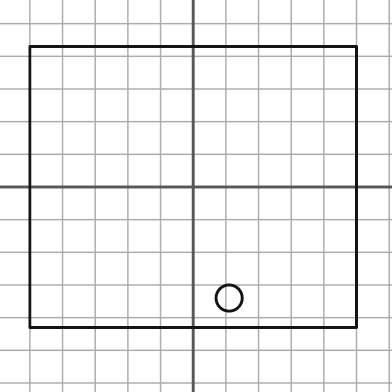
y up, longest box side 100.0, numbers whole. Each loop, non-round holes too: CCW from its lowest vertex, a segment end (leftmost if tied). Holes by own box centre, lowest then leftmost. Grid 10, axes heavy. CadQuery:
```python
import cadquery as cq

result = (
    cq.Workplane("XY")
    .moveTo(-50.0, -43.0)
    .lineTo(50.0, -43.0)
    .lineTo(50.0, 43.0)
    .lineTo(-50.0, 43.0)
    .close()
    .moveTo(11.0, -34.0)
    .circle(4.0)
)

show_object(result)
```